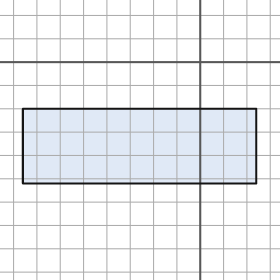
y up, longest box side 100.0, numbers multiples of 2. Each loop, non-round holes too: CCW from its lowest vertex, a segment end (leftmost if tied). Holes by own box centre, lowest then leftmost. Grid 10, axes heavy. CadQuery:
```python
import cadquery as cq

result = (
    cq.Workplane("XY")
    .moveTo(-76.0, -52.0)
    .lineTo(24.0, -52.0)
    .lineTo(24.0, -20.0)
    .lineTo(-76.0, -20.0)
    .close()
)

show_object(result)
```